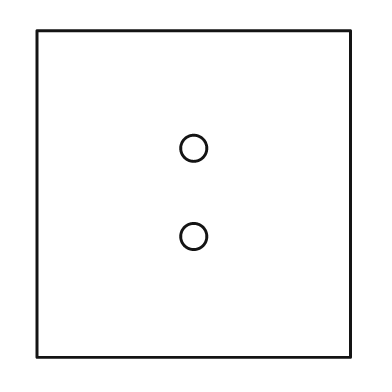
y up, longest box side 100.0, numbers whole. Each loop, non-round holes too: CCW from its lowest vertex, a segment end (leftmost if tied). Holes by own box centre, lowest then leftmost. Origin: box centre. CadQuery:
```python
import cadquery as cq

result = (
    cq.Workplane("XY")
    .moveTo(-48.0, -50.0)
    .lineTo(48.0, -50.0)
    .lineTo(48.0, 50.0)
    .lineTo(-48.0, 50.0)
    .close()
    .moveTo(0.0, -13.0)
    .circle(4.0)
    .moveTo(0.0, 14.0)
    .circle(4.0)
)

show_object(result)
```